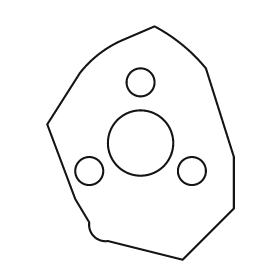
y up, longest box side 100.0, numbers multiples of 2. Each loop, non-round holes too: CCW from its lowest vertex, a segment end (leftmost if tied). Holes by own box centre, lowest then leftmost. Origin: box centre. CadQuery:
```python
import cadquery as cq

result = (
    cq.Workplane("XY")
    .moveTo(18.0, -50.0)
    .lineTo(40.0, -28.0)
    .lineTo(40.0, -6.0)
    .lineTo(28.0, 32.0)
    .threePointArc((18.0, 42.0), (6.0, 50.0))
    .lineTo(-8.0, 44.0)
    .threePointArc((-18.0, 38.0), (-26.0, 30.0))
    .lineTo(-40.0, 8.0)
    .lineTo(-28.0, -24.0)
    .lineTo(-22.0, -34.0)
    .threePointArc((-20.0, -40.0), (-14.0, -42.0))
    .close()
    .moveTo(-22.0, -12.0)
    .circle(6.0)
    .moveTo(22.0, -12.0)
    .circle(6.0)
    .moveTo(0.0, 0.0)
    .circle(14.0)
    .moveTo(0.0, 26.0)
    .circle(6.0)
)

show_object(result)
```